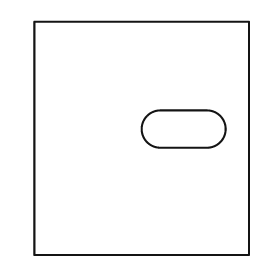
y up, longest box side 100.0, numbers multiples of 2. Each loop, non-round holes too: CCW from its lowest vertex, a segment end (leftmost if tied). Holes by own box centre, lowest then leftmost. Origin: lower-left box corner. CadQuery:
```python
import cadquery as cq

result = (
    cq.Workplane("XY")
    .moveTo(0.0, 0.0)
    .lineTo(92.0, 0.0)
    .lineTo(92.0, 100.0)
    .lineTo(0.0, 100.0)
    .close()
    .moveTo(54.0, 46.0)
    .lineTo(74.0, 46.0)
    .threePointArc((82.0, 54.0), (74.0, 62.0))
    .lineTo(54.0, 62.0)
    .threePointArc((46.0, 54.0), (54.0, 46.0))
    .close()
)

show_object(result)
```